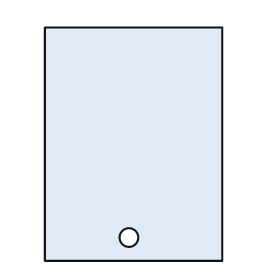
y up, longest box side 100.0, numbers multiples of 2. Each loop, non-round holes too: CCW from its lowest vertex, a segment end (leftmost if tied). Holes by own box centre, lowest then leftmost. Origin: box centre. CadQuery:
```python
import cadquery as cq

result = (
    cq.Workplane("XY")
    .moveTo(-38.0, -50.0)
    .lineTo(38.0, -50.0)
    .lineTo(38.0, 50.0)
    .lineTo(-38.0, 50.0)
    .close()
    .moveTo(-2.0, -40.0)
    .circle(4.0)
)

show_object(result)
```